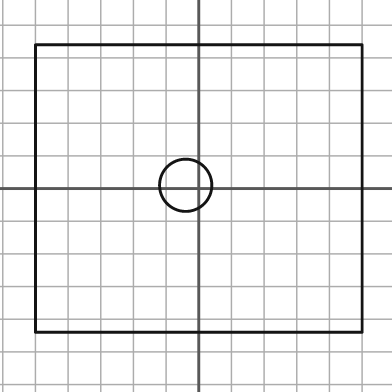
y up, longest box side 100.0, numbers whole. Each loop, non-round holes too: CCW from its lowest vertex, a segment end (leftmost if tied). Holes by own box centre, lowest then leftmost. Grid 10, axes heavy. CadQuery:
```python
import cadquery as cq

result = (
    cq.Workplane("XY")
    .moveTo(-50.0, -44.0)
    .lineTo(50.0, -44.0)
    .lineTo(50.0, 44.0)
    .lineTo(-50.0, 44.0)
    .close()
    .moveTo(-4.0, 1.0)
    .circle(8.0)
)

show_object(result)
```